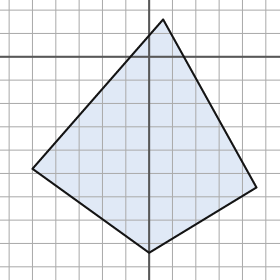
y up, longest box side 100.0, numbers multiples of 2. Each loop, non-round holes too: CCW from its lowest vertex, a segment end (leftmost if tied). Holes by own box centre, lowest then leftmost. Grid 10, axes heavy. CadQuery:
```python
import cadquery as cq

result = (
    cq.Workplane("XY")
    .moveTo(0.0, -84.0)
    .lineTo(46.0, -56.0)
    .lineTo(6.0, 16.0)
    .lineTo(-50.0, -48.0)
    .close()
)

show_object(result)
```